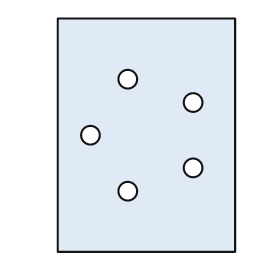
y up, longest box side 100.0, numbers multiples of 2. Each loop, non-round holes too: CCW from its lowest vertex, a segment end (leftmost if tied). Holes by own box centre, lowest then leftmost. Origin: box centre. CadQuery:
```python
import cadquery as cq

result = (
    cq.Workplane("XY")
    .moveTo(-38.0, -50.0)
    .lineTo(38.0, -50.0)
    .lineTo(38.0, 50.0)
    .lineTo(-38.0, 50.0)
    .close()
    .moveTo(-8.0, -24.0)
    .circle(4.0)
    .moveTo(20.0, -14.0)
    .circle(4.0)
    .moveTo(-24.0, 0.0)
    .circle(4.0)
    .moveTo(20.0, 14.0)
    .circle(4.0)
    .moveTo(-8.0, 24.0)
    .circle(4.0)
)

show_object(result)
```